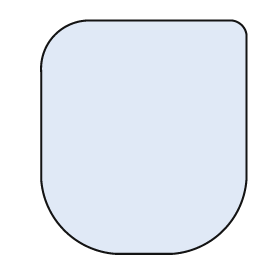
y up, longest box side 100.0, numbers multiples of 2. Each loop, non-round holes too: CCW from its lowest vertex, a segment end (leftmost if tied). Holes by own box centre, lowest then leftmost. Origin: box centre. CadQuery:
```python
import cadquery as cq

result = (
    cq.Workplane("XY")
    .moveTo(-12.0, -50.0)
    .lineTo(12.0, -50.0)
    .threePointArc((34.0, -40.0), (44.0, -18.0))
    .lineTo(44.0, 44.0)
    .threePointArc((42.0, 48.0), (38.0, 50.0))
    .lineTo(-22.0, 50.0)
    .threePointArc((-38.0, 44.0), (-44.0, 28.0))
    .lineTo(-44.0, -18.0)
    .threePointArc((-34.0, -40.0), (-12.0, -50.0))
    .close()
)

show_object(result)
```